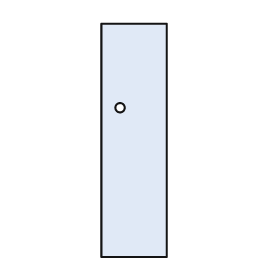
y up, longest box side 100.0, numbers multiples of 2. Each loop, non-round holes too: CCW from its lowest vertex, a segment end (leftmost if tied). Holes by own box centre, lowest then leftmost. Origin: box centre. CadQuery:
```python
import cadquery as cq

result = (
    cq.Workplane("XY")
    .moveTo(-14.0, -50.0)
    .lineTo(14.0, -50.0)
    .lineTo(14.0, 50.0)
    .lineTo(-14.0, 50.0)
    .close()
    .moveTo(-6.0, 14.0)
    .circle(2.0)
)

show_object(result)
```